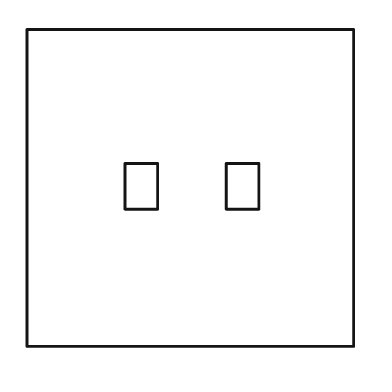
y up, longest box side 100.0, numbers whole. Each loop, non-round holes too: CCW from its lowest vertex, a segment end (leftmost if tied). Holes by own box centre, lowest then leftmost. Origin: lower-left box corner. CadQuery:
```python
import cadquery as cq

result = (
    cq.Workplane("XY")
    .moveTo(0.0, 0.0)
    .lineTo(100.0, 0.0)
    .lineTo(100.0, 97.0)
    .lineTo(0.0, 97.0)
    .close()
    .moveTo(30.0, 42.0)
    .lineTo(40.0, 42.0)
    .lineTo(40.0, 56.0)
    .lineTo(30.0, 56.0)
    .close()
    .moveTo(61.0, 42.0)
    .lineTo(71.0, 42.0)
    .lineTo(71.0, 56.0)
    .lineTo(61.0, 56.0)
    .close()
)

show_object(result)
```